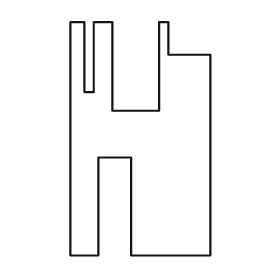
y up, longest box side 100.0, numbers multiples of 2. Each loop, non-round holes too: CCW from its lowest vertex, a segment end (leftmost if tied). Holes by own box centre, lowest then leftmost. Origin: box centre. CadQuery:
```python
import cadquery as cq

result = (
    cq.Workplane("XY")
    .moveTo(-30.0, -50.0)
    .lineTo(-18.0, -50.0)
    .lineTo(-18.0, -8.0)
    .lineTo(-4.0, -8.0)
    .lineTo(-4.0, -50.0)
    .lineTo(30.0, -50.0)
    .lineTo(30.0, 36.0)
    .lineTo(12.0, 36.0)
    .lineTo(12.0, 50.0)
    .lineTo(8.0, 50.0)
    .lineTo(8.0, 12.0)
    .lineTo(-12.0, 12.0)
    .lineTo(-12.0, 50.0)
    .lineTo(-20.0, 50.0)
    .lineTo(-20.0, 20.0)
    .lineTo(-24.0, 20.0)
    .lineTo(-24.0, 50.0)
    .lineTo(-30.0, 50.0)
    .close()
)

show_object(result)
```